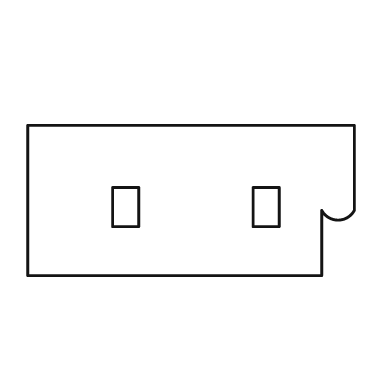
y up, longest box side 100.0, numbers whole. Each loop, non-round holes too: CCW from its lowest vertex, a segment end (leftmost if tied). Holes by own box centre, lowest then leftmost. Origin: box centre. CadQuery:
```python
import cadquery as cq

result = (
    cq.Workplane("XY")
    .moveTo(-50.0, -23.0)
    .lineTo(40.0, -23.0)
    .lineTo(40.0, -3.0)
    .threePointArc((45.0, -6.0), (50.0, -3.0))
    .lineTo(50.0, 23.0)
    .lineTo(-50.0, 23.0)
    .close()
    .moveTo(-24.0, -8.0)
    .lineTo(-16.0, -8.0)
    .lineTo(-16.0, 4.0)
    .lineTo(-24.0, 4.0)
    .close()
    .moveTo(19.0, -8.0)
    .lineTo(27.0, -8.0)
    .lineTo(27.0, 4.0)
    .lineTo(19.0, 4.0)
    .close()
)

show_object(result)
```